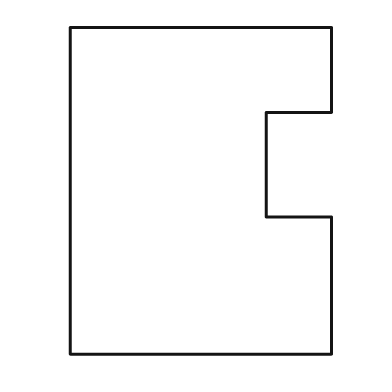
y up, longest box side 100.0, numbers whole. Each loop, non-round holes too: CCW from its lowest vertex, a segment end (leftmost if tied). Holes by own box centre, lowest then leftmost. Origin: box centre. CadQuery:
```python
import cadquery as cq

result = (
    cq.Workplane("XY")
    .moveTo(-40.0, -50.0)
    .lineTo(40.0, -50.0)
    .lineTo(40.0, -8.0)
    .lineTo(20.0, -8.0)
    .lineTo(20.0, 24.0)
    .lineTo(40.0, 24.0)
    .lineTo(40.0, 50.0)
    .lineTo(-40.0, 50.0)
    .close()
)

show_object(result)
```